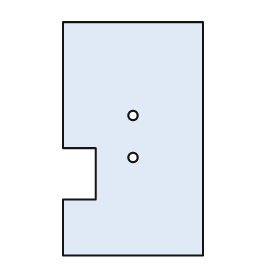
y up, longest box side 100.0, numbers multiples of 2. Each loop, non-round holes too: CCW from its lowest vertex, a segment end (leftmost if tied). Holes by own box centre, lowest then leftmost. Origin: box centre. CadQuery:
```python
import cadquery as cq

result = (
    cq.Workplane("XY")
    .moveTo(-30.0, -50.0)
    .lineTo(30.0, -50.0)
    .lineTo(30.0, 50.0)
    .lineTo(-30.0, 50.0)
    .lineTo(-30.0, -4.0)
    .lineTo(-16.0, -4.0)
    .lineTo(-16.0, -26.0)
    .lineTo(-30.0, -26.0)
    .close()
    .moveTo(0.0, -8.0)
    .circle(2.0)
    .moveTo(0.0, 10.0)
    .circle(2.0)
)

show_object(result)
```